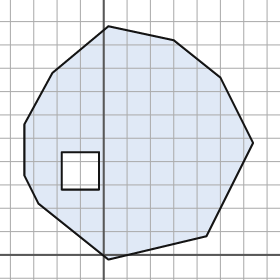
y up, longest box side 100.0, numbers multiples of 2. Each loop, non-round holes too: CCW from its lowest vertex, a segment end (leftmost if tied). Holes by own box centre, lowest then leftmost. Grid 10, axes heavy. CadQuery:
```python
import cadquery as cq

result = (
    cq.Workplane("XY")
    .moveTo(2.0, -2.0)
    .lineTo(44.0, 8.0)
    .lineTo(64.0, 48.0)
    .lineTo(50.0, 76.0)
    .lineTo(30.0, 92.0)
    .lineTo(2.0, 98.0)
    .lineTo(-22.0, 78.0)
    .lineTo(-34.0, 56.0)
    .lineTo(-34.0, 34.0)
    .lineTo(-28.0, 22.0)
    .close()
    .moveTo(-18.0, 28.0)
    .lineTo(-2.0, 28.0)
    .lineTo(-2.0, 44.0)
    .lineTo(-18.0, 44.0)
    .close()
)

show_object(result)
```